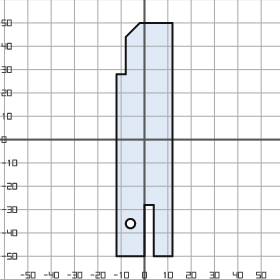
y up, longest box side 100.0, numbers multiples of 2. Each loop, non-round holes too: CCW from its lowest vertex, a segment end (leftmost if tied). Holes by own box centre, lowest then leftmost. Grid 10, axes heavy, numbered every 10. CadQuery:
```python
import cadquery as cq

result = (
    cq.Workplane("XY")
    .moveTo(-12.0, -50.0)
    .lineTo(0.0, -50.0)
    .lineTo(0.0, -28.0)
    .lineTo(4.0, -28.0)
    .lineTo(4.0, -50.0)
    .lineTo(12.0, -50.0)
    .lineTo(12.0, 50.0)
    .lineTo(-2.0, 50.0)
    .lineTo(-8.0, 44.0)
    .lineTo(-8.0, 28.0)
    .lineTo(-12.0, 28.0)
    .close()
    .moveTo(-6.0, -36.0)
    .circle(2.0)
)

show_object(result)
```